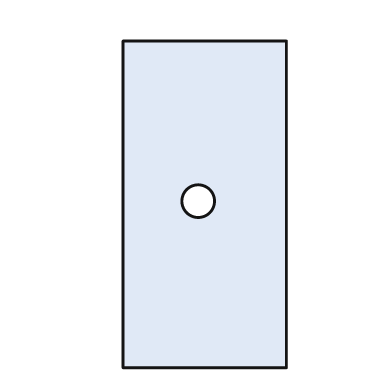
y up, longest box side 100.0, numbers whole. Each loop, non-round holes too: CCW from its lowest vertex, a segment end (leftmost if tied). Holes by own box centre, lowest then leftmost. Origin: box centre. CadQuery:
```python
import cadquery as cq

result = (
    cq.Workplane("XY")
    .moveTo(-25.0, -50.0)
    .lineTo(25.0, -50.0)
    .lineTo(25.0, 50.0)
    .lineTo(-25.0, 50.0)
    .close()
    .moveTo(-2.0, 1.0)
    .circle(5.0)
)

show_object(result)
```